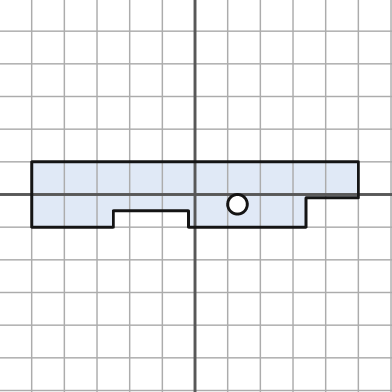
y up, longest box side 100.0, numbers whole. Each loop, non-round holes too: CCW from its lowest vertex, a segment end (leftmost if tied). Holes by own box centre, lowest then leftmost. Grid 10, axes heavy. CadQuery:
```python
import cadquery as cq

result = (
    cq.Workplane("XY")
    .moveTo(-50.0, -10.0)
    .lineTo(-25.0, -10.0)
    .lineTo(-25.0, -5.0)
    .lineTo(-2.0, -5.0)
    .lineTo(-2.0, -10.0)
    .lineTo(34.0, -10.0)
    .lineTo(34.0, -1.0)
    .lineTo(50.0, -1.0)
    .lineTo(50.0, 10.0)
    .lineTo(-50.0, 10.0)
    .close()
    .moveTo(13.0, -3.0)
    .circle(3.0)
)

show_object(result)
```